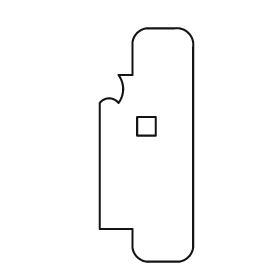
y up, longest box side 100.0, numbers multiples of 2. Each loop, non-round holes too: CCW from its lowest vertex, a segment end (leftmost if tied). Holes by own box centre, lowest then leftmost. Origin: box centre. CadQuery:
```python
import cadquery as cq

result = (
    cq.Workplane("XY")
    .moveTo(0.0, -50.0)
    .lineTo(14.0, -50.0)
    .threePointArc((18.0, -48.0), (20.0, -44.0))
    .lineTo(20.0, 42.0)
    .threePointArc((18.0, 48.0), (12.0, 50.0))
    .lineTo(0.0, 50.0)
    .threePointArc((-4.0, 48.0), (-6.0, 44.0))
    .lineTo(-6.0, 30.0)
    .lineTo(-12.0, 30.0)
    .threePointArc((-10.0, 24.0), (-12.0, 18.0))
    .threePointArc((-16.0, 20.0), (-20.0, 18.0))
    .lineTo(-20.0, -36.0)
    .lineTo(-6.0, -36.0)
    .lineTo(-6.0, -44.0)
    .threePointArc((-4.0, -48.0), (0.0, -50.0))
    .close()
    .moveTo(-4.0, 4.0)
    .lineTo(4.0, 4.0)
    .lineTo(4.0, 12.0)
    .lineTo(-4.0, 12.0)
    .close()
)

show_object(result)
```